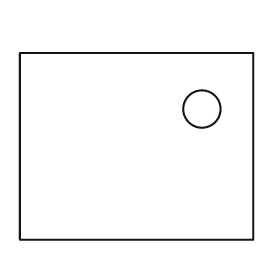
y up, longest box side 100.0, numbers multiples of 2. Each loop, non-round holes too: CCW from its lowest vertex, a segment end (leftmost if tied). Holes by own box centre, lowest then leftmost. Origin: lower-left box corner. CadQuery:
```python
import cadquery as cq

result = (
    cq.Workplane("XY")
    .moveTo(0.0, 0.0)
    .lineTo(100.0, 0.0)
    .lineTo(100.0, 80.0)
    .lineTo(0.0, 80.0)
    .close()
    .moveTo(78.0, 56.0)
    .circle(8.0)
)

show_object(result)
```